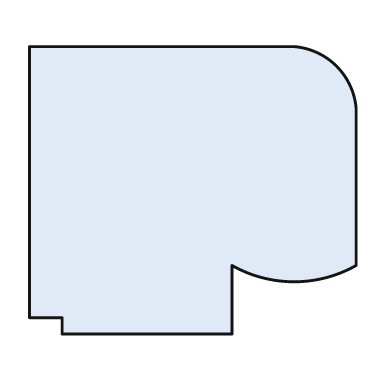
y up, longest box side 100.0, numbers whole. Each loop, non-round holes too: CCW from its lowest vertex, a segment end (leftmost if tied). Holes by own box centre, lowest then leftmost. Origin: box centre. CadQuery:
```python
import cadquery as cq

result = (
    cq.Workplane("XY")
    .moveTo(-40.0, -44.0)
    .lineTo(12.0, -44.0)
    .lineTo(12.0, -23.0)
    .threePointArc((31.0, -28.0), (50.0, -23.0))
    .lineTo(50.0, 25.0)
    .threePointArc((44.0, 38.0), (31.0, 44.0))
    .lineTo(-50.0, 44.0)
    .lineTo(-50.0, -39.0)
    .lineTo(-40.0, -39.0)
    .close()
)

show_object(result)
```